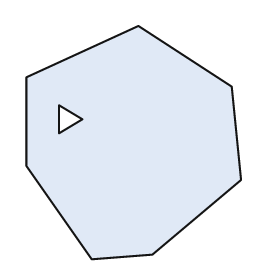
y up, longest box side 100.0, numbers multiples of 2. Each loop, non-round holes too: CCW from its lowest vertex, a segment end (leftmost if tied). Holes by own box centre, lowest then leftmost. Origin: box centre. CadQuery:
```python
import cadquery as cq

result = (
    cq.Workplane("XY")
    .moveTo(-18.0, -50.0)
    .lineTo(8.0, -48.0)
    .lineTo(46.0, -16.0)
    .lineTo(42.0, 24.0)
    .lineTo(2.0, 50.0)
    .lineTo(-46.0, 28.0)
    .lineTo(-46.0, -10.0)
    .close()
    .moveTo(-32.0, 4.0)
    .lineTo(-22.0, 10.0)
    .lineTo(-32.0, 16.0)
    .close()
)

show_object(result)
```